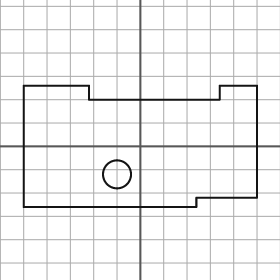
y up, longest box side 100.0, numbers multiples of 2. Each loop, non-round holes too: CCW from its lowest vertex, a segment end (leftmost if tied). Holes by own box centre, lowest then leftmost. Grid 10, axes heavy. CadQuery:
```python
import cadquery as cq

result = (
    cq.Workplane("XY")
    .moveTo(-50.0, -26.0)
    .lineTo(24.0, -26.0)
    .lineTo(24.0, -22.0)
    .lineTo(50.0, -22.0)
    .lineTo(50.0, 26.0)
    .lineTo(34.0, 26.0)
    .lineTo(34.0, 20.0)
    .lineTo(-22.0, 20.0)
    .lineTo(-22.0, 26.0)
    .lineTo(-50.0, 26.0)
    .close()
    .moveTo(-10.0, -12.0)
    .circle(6.0)
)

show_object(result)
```